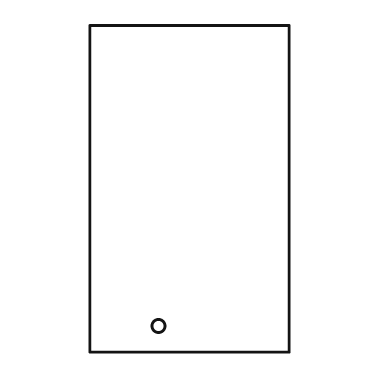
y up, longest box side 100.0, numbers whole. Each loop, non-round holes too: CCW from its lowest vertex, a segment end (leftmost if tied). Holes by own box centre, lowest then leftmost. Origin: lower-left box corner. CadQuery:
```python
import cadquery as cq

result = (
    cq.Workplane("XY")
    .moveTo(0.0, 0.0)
    .lineTo(61.0, 0.0)
    .lineTo(61.0, 100.0)
    .lineTo(0.0, 100.0)
    .close()
    .moveTo(21.0, 8.0)
    .circle(2.0)
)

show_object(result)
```